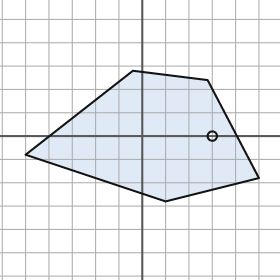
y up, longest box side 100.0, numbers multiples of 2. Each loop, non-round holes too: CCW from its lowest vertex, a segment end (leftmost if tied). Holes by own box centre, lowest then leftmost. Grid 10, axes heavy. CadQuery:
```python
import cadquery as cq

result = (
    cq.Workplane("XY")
    .moveTo(10.0, -28.0)
    .lineTo(50.0, -18.0)
    .lineTo(28.0, 24.0)
    .lineTo(-4.0, 28.0)
    .lineTo(-50.0, -8.0)
    .close()
    .moveTo(30.0, 0.0)
    .circle(2.0)
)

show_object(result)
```